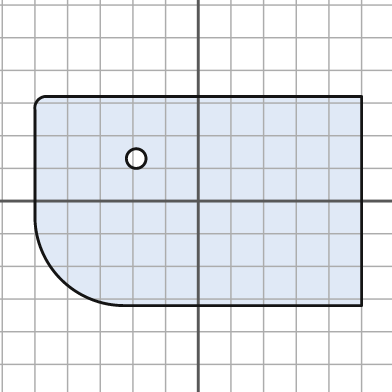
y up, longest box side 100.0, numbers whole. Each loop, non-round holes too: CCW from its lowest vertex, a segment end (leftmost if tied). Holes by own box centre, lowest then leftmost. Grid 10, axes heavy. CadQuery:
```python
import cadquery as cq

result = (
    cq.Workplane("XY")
    .moveTo(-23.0, -32.0)
    .lineTo(50.0, -32.0)
    .lineTo(50.0, 32.0)
    .lineTo(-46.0, 32.0)
    .threePointArc((-49.0, 31.0), (-50.0, 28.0))
    .lineTo(-50.0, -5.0)
    .threePointArc((-42.0, -24.0), (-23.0, -32.0))
    .close()
    .moveTo(-19.0, 13.0)
    .circle(3.0)
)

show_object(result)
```